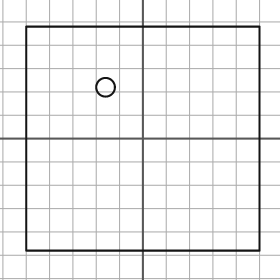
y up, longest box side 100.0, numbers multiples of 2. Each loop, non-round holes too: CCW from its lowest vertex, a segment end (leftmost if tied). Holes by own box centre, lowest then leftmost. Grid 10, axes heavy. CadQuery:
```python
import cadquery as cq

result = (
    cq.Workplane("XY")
    .moveTo(-50.0, -48.0)
    .lineTo(50.0, -48.0)
    .lineTo(50.0, 48.0)
    .lineTo(-50.0, 48.0)
    .close()
    .moveTo(-16.0, 22.0)
    .circle(4.0)
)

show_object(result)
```